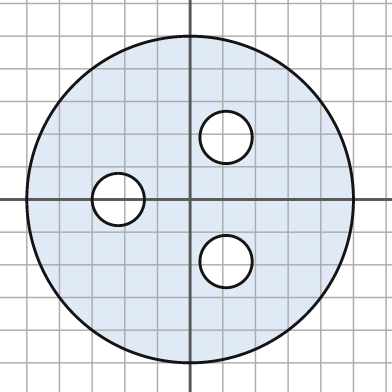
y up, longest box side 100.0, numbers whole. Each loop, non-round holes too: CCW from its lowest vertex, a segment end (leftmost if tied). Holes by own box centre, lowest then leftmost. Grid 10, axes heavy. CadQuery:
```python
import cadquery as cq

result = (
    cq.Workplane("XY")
    .moveTo(0.0, 0.0)
    .circle(50.0)
    .moveTo(11.0, -19.0)
    .circle(8.0)
    .moveTo(-22.0, 0.0)
    .circle(8.0)
    .moveTo(11.0, 19.0)
    .circle(8.0)
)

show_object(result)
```